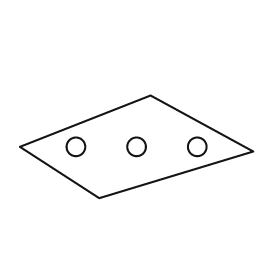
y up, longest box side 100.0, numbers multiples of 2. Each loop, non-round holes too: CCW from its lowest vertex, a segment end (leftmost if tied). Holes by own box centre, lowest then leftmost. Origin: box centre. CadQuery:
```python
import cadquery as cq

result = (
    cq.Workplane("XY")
    .moveTo(-16.0, -22.0)
    .lineTo(50.0, -2.0)
    .lineTo(6.0, 22.0)
    .lineTo(-50.0, 0.0)
    .close()
    .moveTo(-26.0, 0.0)
    .circle(4.0)
    .moveTo(0.0, 0.0)
    .circle(4.0)
    .moveTo(26.0, 0.0)
    .circle(4.0)
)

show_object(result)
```